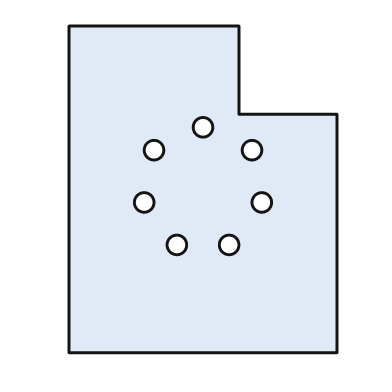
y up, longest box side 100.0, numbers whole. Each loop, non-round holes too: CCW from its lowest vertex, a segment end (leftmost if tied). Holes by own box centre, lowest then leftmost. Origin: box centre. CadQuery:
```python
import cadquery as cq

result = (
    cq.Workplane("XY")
    .moveTo(-41.0, -50.0)
    .lineTo(41.0, -50.0)
    .lineTo(41.0, 23.0)
    .lineTo(11.0, 23.0)
    .lineTo(11.0, 50.0)
    .lineTo(-41.0, 50.0)
    .close()
    .moveTo(-8.0, -17.0)
    .circle(3.0)
    .moveTo(8.0, -17.0)
    .circle(3.0)
    .moveTo(-18.0, -4.0)
    .circle(3.0)
    .moveTo(18.0, -4.0)
    .circle(3.0)
    .moveTo(-15.0, 12.0)
    .circle(3.0)
    .moveTo(15.0, 12.0)
    .circle(3.0)
    .moveTo(0.0, 19.0)
    .circle(3.0)
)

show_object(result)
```